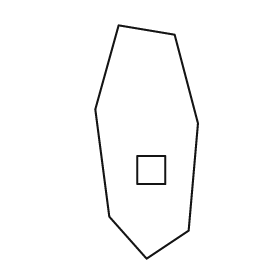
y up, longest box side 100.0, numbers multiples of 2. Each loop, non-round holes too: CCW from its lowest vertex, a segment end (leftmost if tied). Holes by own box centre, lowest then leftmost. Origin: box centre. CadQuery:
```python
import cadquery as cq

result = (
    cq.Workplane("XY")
    .moveTo(0.0, -50.0)
    .lineTo(18.0, -38.0)
    .lineTo(22.0, 8.0)
    .lineTo(12.0, 46.0)
    .lineTo(-12.0, 50.0)
    .lineTo(-22.0, 14.0)
    .lineTo(-16.0, -32.0)
    .close()
    .moveTo(-4.0, -18.0)
    .lineTo(8.0, -18.0)
    .lineTo(8.0, -6.0)
    .lineTo(-4.0, -6.0)
    .close()
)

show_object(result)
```